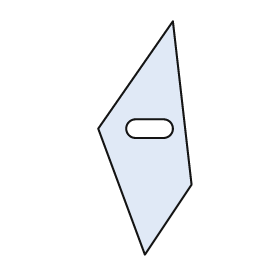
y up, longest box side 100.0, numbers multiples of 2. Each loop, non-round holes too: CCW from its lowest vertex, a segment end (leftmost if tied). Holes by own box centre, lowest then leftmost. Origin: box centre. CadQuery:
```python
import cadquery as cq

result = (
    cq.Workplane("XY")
    .moveTo(0.0, -50.0)
    .lineTo(20.0, -20.0)
    .lineTo(12.0, 50.0)
    .lineTo(-20.0, 4.0)
    .close()
    .moveTo(-4.0, 0.0)
    .lineTo(8.0, 0.0)
    .threePointArc((12.0, 4.0), (8.0, 8.0))
    .lineTo(-4.0, 8.0)
    .threePointArc((-8.0, 4.0), (-4.0, 0.0))
    .close()
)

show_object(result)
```